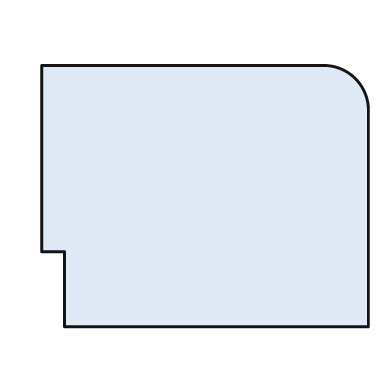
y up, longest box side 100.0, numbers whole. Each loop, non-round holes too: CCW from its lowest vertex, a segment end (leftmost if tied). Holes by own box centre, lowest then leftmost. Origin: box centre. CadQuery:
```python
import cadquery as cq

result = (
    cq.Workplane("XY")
    .moveTo(-43.0, -40.0)
    .lineTo(50.0, -40.0)
    .lineTo(50.0, 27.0)
    .threePointArc((46.0, 36.0), (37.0, 40.0))
    .lineTo(-50.0, 40.0)
    .lineTo(-50.0, -17.0)
    .lineTo(-43.0, -17.0)
    .close()
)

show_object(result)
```